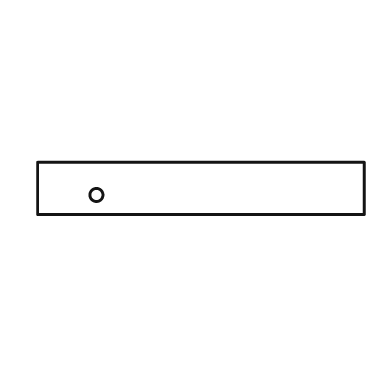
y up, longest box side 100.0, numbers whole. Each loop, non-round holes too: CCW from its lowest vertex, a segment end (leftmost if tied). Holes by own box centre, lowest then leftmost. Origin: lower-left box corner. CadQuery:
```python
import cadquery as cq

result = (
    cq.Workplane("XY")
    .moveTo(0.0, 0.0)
    .lineTo(100.0, 0.0)
    .lineTo(100.0, 16.0)
    .lineTo(0.0, 16.0)
    .close()
    .moveTo(18.0, 6.0)
    .circle(2.0)
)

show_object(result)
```